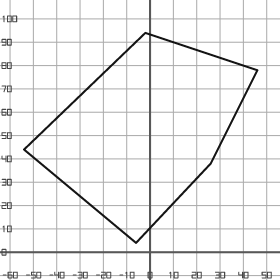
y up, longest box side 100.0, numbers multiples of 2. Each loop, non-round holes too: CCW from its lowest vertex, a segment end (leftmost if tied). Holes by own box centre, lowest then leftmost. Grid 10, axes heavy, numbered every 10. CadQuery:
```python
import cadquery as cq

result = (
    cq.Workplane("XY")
    .moveTo(-6.0, 4.0)
    .lineTo(26.0, 38.0)
    .lineTo(46.0, 78.0)
    .lineTo(-2.0, 94.0)
    .lineTo(-54.0, 44.0)
    .close()
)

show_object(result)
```